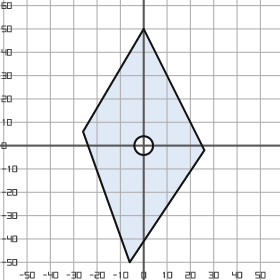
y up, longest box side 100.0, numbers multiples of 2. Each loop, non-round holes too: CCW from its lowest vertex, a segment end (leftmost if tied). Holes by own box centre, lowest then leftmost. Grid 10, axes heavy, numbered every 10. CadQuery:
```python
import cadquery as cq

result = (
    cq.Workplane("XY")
    .moveTo(-6.0, -50.0)
    .lineTo(26.0, -2.0)
    .lineTo(0.0, 50.0)
    .lineTo(-26.0, 6.0)
    .close()
    .moveTo(0.0, 0.0)
    .circle(4.0)
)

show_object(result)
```